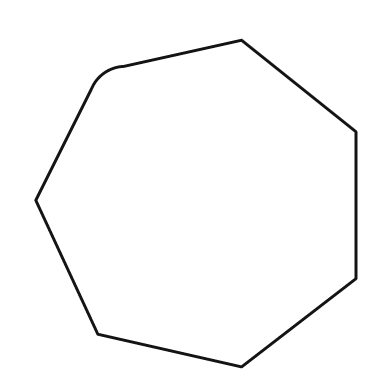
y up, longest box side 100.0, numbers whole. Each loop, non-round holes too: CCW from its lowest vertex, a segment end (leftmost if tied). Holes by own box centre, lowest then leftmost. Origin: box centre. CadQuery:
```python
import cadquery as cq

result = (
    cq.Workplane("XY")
    .moveTo(14.0, -50.0)
    .lineTo(49.0, -23.0)
    .lineTo(49.0, 22.0)
    .lineTo(14.0, 50.0)
    .lineTo(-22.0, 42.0)
    .threePointArc((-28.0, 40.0), (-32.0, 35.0))
    .lineTo(-49.0, 1.0)
    .lineTo(-30.0, -40.0)
    .close()
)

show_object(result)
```